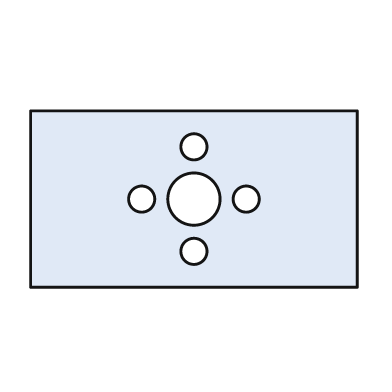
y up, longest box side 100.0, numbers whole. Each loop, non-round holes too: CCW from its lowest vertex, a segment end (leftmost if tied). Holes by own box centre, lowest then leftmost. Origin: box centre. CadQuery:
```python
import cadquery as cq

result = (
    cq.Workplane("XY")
    .moveTo(-50.0, -27.0)
    .lineTo(50.0, -27.0)
    .lineTo(50.0, 27.0)
    .lineTo(-50.0, 27.0)
    .close()
    .moveTo(0.0, -16.0)
    .circle(4.0)
    .moveTo(-16.0, 0.0)
    .circle(4.0)
    .moveTo(0.0, 0.0)
    .circle(8.0)
    .moveTo(16.0, 0.0)
    .circle(4.0)
    .moveTo(0.0, 16.0)
    .circle(4.0)
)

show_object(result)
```